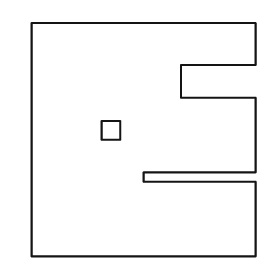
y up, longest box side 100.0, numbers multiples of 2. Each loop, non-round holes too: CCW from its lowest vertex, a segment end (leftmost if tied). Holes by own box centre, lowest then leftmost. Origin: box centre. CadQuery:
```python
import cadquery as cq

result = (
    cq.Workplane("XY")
    .moveTo(-48.0, -50.0)
    .lineTo(48.0, -50.0)
    .lineTo(48.0, -18.0)
    .lineTo(0.0, -18.0)
    .lineTo(0.0, -14.0)
    .lineTo(48.0, -14.0)
    .lineTo(48.0, 18.0)
    .lineTo(16.0, 18.0)
    .lineTo(16.0, 32.0)
    .lineTo(48.0, 32.0)
    .lineTo(48.0, 50.0)
    .lineTo(-48.0, 50.0)
    .close()
    .moveTo(-18.0, 0.0)
    .lineTo(-10.0, 0.0)
    .lineTo(-10.0, 8.0)
    .lineTo(-18.0, 8.0)
    .close()
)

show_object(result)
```